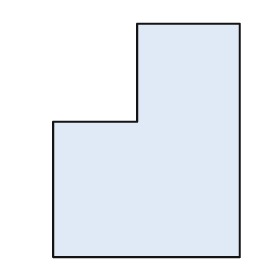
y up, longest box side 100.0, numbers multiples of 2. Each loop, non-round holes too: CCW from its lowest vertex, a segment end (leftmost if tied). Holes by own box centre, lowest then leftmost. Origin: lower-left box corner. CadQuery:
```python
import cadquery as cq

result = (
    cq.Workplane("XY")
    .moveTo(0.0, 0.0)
    .lineTo(80.0, 0.0)
    .lineTo(80.0, 100.0)
    .lineTo(36.0, 100.0)
    .lineTo(36.0, 58.0)
    .lineTo(0.0, 58.0)
    .close()
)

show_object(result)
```